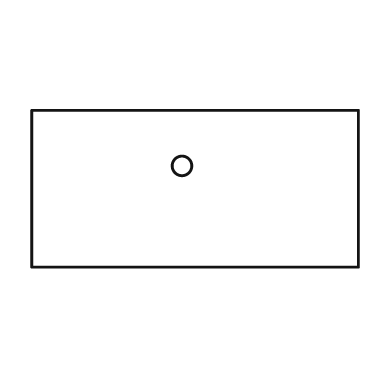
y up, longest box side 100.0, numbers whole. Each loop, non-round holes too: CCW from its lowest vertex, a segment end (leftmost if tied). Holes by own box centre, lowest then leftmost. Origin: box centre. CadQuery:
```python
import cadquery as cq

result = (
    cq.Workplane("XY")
    .moveTo(-50.0, -24.0)
    .lineTo(50.0, -24.0)
    .lineTo(50.0, 24.0)
    .lineTo(-50.0, 24.0)
    .close()
    .moveTo(-4.0, 7.0)
    .circle(3.0)
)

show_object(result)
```